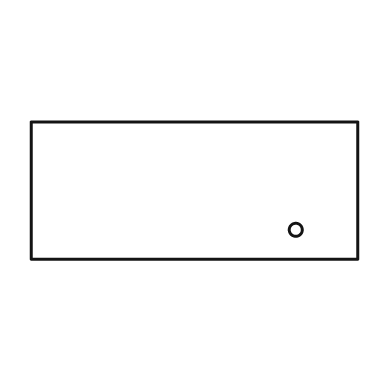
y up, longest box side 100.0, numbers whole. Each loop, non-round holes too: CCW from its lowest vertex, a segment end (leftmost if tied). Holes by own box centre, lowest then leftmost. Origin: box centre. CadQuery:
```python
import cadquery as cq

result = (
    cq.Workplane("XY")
    .moveTo(-50.0, -21.0)
    .lineTo(50.0, -21.0)
    .lineTo(50.0, 21.0)
    .lineTo(-50.0, 21.0)
    .close()
    .moveTo(31.0, -12.0)
    .circle(2.0)
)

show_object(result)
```